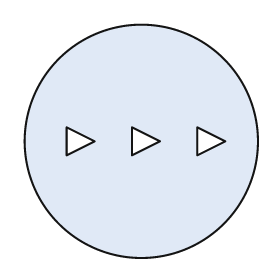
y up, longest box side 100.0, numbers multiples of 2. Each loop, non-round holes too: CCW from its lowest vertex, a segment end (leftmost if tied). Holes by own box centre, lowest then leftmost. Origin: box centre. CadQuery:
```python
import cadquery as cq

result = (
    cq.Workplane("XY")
    .moveTo(0.0, 0.0)
    .circle(50.0)
    .moveTo(-32.0, -6.0)
    .lineTo(-20.0, 0.0)
    .lineTo(-32.0, 6.0)
    .close()
    .moveTo(-4.0, -6.0)
    .lineTo(8.0, 0.0)
    .lineTo(-4.0, 6.0)
    .close()
    .moveTo(24.0, -6.0)
    .lineTo(36.0, 0.0)
    .lineTo(24.0, 6.0)
    .close()
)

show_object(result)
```